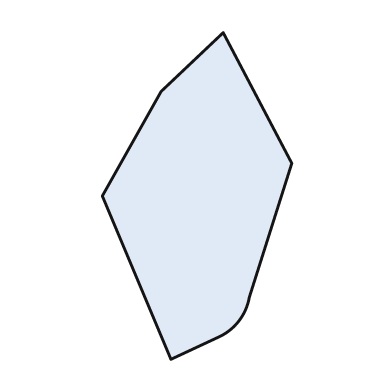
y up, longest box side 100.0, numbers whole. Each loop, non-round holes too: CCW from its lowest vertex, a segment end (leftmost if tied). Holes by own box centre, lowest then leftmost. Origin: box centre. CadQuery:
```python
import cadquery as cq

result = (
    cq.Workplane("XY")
    .moveTo(-8.0, -50.0)
    .lineTo(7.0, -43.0)
    .threePointArc((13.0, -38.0), (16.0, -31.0))
    .lineTo(29.0, 10.0)
    .lineTo(8.0, 50.0)
    .lineTo(-11.0, 32.0)
    .lineTo(-29.0, 0.0)
    .close()
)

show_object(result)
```